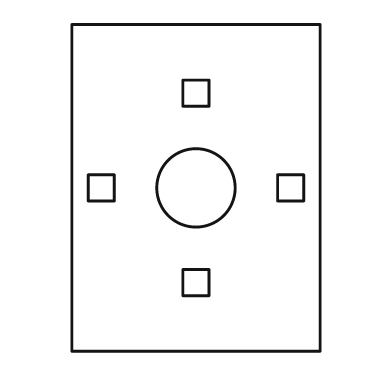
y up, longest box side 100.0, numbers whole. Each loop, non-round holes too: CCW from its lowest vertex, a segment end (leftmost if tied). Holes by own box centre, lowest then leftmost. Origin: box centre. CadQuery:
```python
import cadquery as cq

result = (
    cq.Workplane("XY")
    .moveTo(-38.0, -50.0)
    .lineTo(38.0, -50.0)
    .lineTo(38.0, 50.0)
    .lineTo(-38.0, 50.0)
    .close()
    .moveTo(-4.0, -33.0)
    .lineTo(4.0, -33.0)
    .lineTo(4.0, -25.0)
    .lineTo(-4.0, -25.0)
    .close()
    .moveTo(-33.0, -4.0)
    .lineTo(-25.0, -4.0)
    .lineTo(-25.0, 4.0)
    .lineTo(-33.0, 4.0)
    .close()
    .moveTo(0.0, 0.0)
    .circle(12.0)
    .moveTo(25.0, -4.0)
    .lineTo(33.0, -4.0)
    .lineTo(33.0, 4.0)
    .lineTo(25.0, 4.0)
    .close()
    .moveTo(-4.0, 25.0)
    .lineTo(4.0, 25.0)
    .lineTo(4.0, 33.0)
    .lineTo(-4.0, 33.0)
    .close()
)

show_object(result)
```